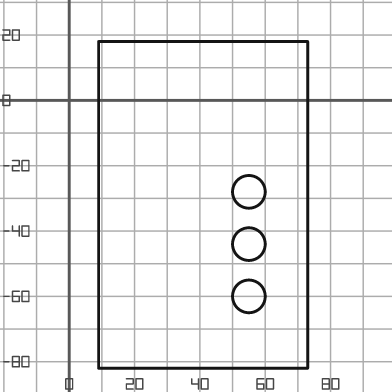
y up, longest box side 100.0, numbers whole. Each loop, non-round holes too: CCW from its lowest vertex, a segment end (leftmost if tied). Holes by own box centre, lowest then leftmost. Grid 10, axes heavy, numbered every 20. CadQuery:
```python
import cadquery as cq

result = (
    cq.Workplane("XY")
    .moveTo(9.0, -82.0)
    .lineTo(73.0, -82.0)
    .lineTo(73.0, 18.0)
    .lineTo(9.0, 18.0)
    .close()
    .moveTo(55.0, -60.0)
    .circle(5.0)
    .moveTo(55.0, -44.0)
    .circle(5.0)
    .moveTo(55.0, -28.0)
    .circle(5.0)
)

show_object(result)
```